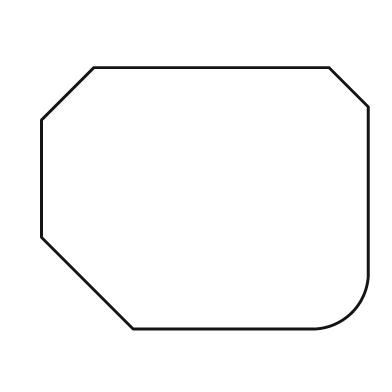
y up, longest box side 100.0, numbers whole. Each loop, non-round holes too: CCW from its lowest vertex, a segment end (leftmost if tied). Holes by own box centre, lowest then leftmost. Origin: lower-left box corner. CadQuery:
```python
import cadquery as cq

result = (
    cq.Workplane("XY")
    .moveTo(28.0, 0.0)
    .lineTo(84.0, 0.0)
    .threePointArc((95.0, 5.0), (100.0, 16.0))
    .lineTo(100.0, 68.0)
    .lineTo(88.0, 80.0)
    .lineTo(16.0, 80.0)
    .lineTo(0.0, 64.0)
    .lineTo(0.0, 28.0)
    .close()
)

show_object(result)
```